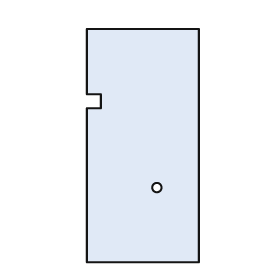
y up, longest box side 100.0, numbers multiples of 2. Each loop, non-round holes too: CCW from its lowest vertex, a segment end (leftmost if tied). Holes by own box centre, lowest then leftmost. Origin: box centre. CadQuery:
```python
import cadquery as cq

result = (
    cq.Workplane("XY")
    .moveTo(-24.0, -50.0)
    .lineTo(24.0, -50.0)
    .lineTo(24.0, 50.0)
    .lineTo(-24.0, 50.0)
    .lineTo(-24.0, 22.0)
    .lineTo(-18.0, 22.0)
    .lineTo(-18.0, 16.0)
    .lineTo(-24.0, 16.0)
    .close()
    .moveTo(6.0, -18.0)
    .circle(2.0)
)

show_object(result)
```